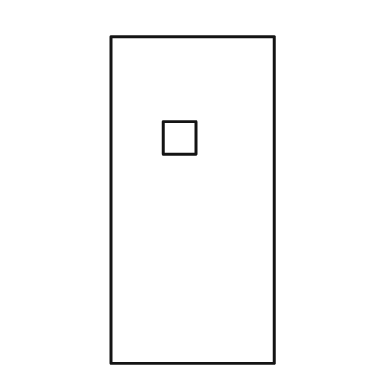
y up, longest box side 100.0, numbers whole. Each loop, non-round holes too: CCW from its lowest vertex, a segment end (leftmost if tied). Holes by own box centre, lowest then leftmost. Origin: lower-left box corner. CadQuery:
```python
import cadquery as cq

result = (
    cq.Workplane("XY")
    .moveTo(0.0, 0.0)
    .lineTo(50.0, 0.0)
    .lineTo(50.0, 100.0)
    .lineTo(0.0, 100.0)
    .close()
    .moveTo(16.0, 64.0)
    .lineTo(26.0, 64.0)
    .lineTo(26.0, 74.0)
    .lineTo(16.0, 74.0)
    .close()
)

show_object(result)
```